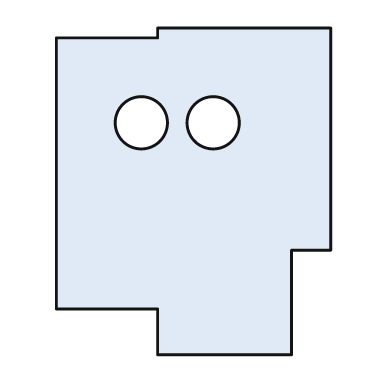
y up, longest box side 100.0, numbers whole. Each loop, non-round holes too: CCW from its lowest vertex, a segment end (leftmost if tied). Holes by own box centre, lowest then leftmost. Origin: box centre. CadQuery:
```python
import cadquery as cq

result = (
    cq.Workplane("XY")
    .moveTo(-11.0, -50.0)
    .lineTo(30.0, -50.0)
    .lineTo(30.0, -18.0)
    .lineTo(42.0, -18.0)
    .lineTo(42.0, 50.0)
    .lineTo(-11.0, 50.0)
    .lineTo(-11.0, 47.0)
    .lineTo(-42.0, 47.0)
    .lineTo(-42.0, -36.0)
    .lineTo(-11.0, -36.0)
    .close()
    .moveTo(-16.0, 21.0)
    .circle(8.0)
    .moveTo(6.0, 21.0)
    .circle(8.0)
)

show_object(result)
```